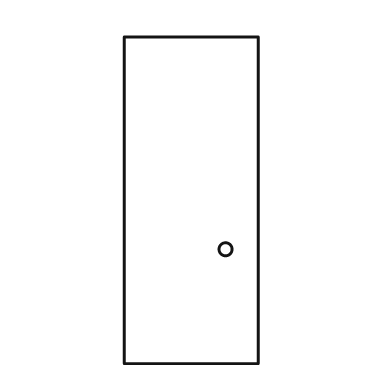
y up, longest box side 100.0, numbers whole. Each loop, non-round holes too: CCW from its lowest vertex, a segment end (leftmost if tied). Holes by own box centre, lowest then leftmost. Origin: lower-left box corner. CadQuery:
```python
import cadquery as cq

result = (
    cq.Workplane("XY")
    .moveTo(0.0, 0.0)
    .lineTo(41.0, 0.0)
    .lineTo(41.0, 100.0)
    .lineTo(0.0, 100.0)
    .close()
    .moveTo(31.0, 35.0)
    .circle(2.0)
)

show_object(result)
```